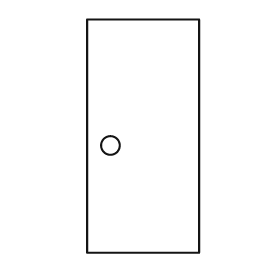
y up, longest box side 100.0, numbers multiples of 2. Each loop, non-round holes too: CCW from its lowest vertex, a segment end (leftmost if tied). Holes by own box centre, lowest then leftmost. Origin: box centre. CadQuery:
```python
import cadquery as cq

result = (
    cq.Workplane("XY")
    .moveTo(-24.0, -50.0)
    .lineTo(24.0, -50.0)
    .lineTo(24.0, 50.0)
    .lineTo(-24.0, 50.0)
    .close()
    .moveTo(-14.0, -4.0)
    .circle(4.0)
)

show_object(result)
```